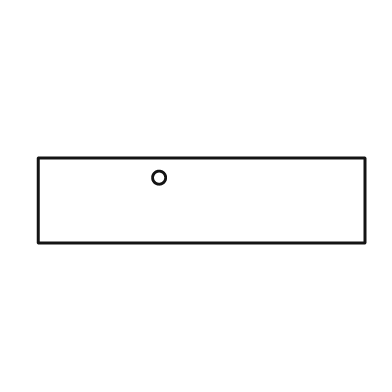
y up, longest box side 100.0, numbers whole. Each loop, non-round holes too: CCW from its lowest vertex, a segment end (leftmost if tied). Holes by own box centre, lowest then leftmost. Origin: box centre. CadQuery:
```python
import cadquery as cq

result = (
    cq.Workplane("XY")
    .moveTo(-50.0, -13.0)
    .lineTo(50.0, -13.0)
    .lineTo(50.0, 13.0)
    .lineTo(-50.0, 13.0)
    .close()
    .moveTo(-13.0, 7.0)
    .circle(2.0)
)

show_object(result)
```